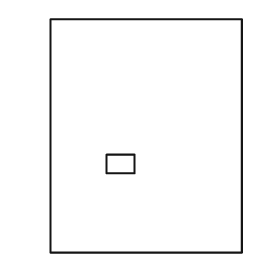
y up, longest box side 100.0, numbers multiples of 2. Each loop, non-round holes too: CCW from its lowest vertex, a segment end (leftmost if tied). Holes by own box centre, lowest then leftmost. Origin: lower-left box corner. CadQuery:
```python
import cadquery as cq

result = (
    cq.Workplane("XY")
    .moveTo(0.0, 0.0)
    .lineTo(82.0, 0.0)
    .lineTo(82.0, 100.0)
    .lineTo(0.0, 100.0)
    .close()
    .moveTo(24.0, 34.0)
    .lineTo(36.0, 34.0)
    .lineTo(36.0, 42.0)
    .lineTo(24.0, 42.0)
    .close()
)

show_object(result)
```